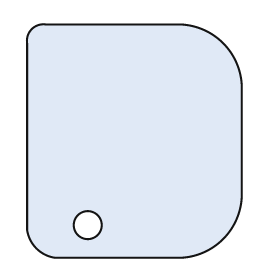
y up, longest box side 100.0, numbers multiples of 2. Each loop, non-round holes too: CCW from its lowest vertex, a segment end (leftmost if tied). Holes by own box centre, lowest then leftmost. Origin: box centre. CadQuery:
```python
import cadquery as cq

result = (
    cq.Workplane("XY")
    .moveTo(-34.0, -50.0)
    .lineTo(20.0, -50.0)
    .threePointArc((38.0, -42.0), (46.0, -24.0))
    .lineTo(46.0, 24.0)
    .threePointArc((38.0, 42.0), (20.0, 50.0))
    .lineTo(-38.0, 50.0)
    .threePointArc((-44.0, 48.0), (-46.0, 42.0))
    .lineTo(-46.0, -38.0)
    .threePointArc((-42.0, -46.0), (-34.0, -50.0))
    .close()
    .moveTo(-20.0, -36.0)
    .circle(6.0)
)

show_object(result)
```